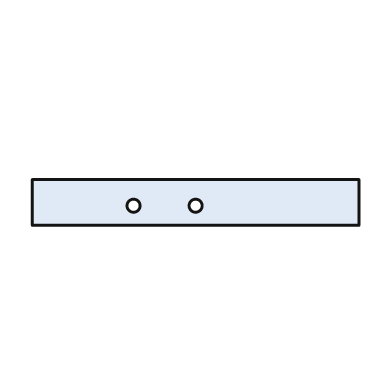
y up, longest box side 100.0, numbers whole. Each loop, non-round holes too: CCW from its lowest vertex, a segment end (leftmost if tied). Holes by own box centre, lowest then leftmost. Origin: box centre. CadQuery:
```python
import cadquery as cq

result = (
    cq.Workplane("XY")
    .moveTo(-50.0, -7.0)
    .lineTo(50.0, -7.0)
    .lineTo(50.0, 7.0)
    .lineTo(-50.0, 7.0)
    .close()
    .moveTo(-19.0, -1.0)
    .circle(2.0)
    .moveTo(0.0, -1.0)
    .circle(2.0)
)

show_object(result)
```